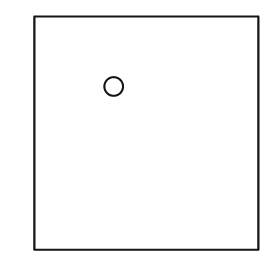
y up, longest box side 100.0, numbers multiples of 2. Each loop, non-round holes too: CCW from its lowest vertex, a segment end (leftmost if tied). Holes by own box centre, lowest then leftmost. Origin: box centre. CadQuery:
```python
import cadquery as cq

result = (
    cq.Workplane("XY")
    .moveTo(-48.0, -50.0)
    .lineTo(48.0, -50.0)
    .lineTo(48.0, 50.0)
    .lineTo(-48.0, 50.0)
    .close()
    .moveTo(-14.0, 20.0)
    .circle(4.0)
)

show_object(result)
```